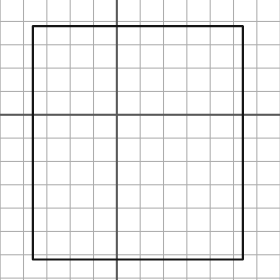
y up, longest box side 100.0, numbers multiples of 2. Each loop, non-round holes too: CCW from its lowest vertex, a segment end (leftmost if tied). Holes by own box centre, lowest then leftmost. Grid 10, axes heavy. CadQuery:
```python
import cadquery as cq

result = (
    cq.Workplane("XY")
    .moveTo(-36.0, -62.0)
    .lineTo(54.0, -62.0)
    .lineTo(54.0, 38.0)
    .lineTo(-36.0, 38.0)
    .close()
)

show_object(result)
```